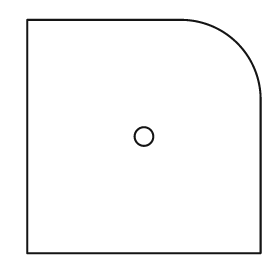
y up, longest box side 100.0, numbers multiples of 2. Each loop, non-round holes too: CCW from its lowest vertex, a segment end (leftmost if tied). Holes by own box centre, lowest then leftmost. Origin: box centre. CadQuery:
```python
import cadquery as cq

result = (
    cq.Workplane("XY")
    .moveTo(-50.0, -50.0)
    .lineTo(50.0, -50.0)
    .lineTo(50.0, 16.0)
    .threePointArc((40.0, 40.0), (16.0, 50.0))
    .lineTo(-50.0, 50.0)
    .close()
    .moveTo(0.0, 0.0)
    .circle(4.0)
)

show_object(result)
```